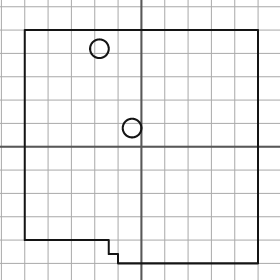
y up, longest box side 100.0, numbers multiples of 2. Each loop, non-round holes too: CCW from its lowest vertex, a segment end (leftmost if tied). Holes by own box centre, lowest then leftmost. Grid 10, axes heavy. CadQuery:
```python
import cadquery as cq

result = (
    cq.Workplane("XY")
    .moveTo(-10.0, -50.0)
    .lineTo(50.0, -50.0)
    .lineTo(50.0, 50.0)
    .lineTo(-50.0, 50.0)
    .lineTo(-50.0, -40.0)
    .lineTo(-14.0, -40.0)
    .lineTo(-14.0, -46.0)
    .lineTo(-10.0, -46.0)
    .close()
    .moveTo(-4.0, 8.0)
    .circle(4.0)
    .moveTo(-18.0, 42.0)
    .circle(4.0)
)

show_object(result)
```